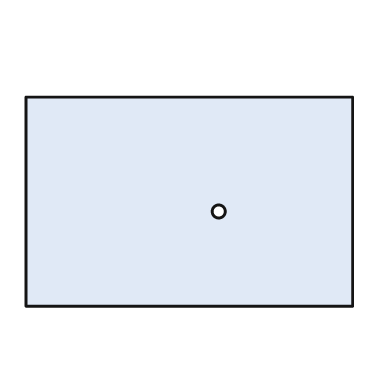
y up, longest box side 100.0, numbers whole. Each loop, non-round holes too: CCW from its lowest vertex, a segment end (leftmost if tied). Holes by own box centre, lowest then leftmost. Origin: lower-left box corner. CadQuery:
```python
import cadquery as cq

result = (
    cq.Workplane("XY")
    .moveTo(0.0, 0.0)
    .lineTo(100.0, 0.0)
    .lineTo(100.0, 64.0)
    .lineTo(0.0, 64.0)
    .close()
    .moveTo(59.0, 29.0)
    .circle(2.0)
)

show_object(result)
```